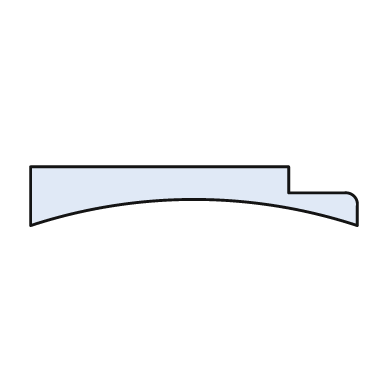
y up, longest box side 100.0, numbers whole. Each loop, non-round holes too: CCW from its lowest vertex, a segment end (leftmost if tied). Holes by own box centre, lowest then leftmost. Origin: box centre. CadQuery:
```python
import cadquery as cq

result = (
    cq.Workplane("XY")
    .moveTo(-50.0, -9.0)
    .threePointArc((0.0, -1.0), (50.0, -9.0))
    .lineTo(50.0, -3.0)
    .threePointArc((49.0, 0.0), (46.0, 1.0))
    .lineTo(29.0, 1.0)
    .lineTo(29.0, 9.0)
    .lineTo(-50.0, 9.0)
    .close()
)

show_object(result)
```